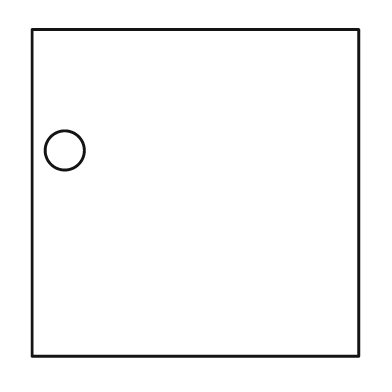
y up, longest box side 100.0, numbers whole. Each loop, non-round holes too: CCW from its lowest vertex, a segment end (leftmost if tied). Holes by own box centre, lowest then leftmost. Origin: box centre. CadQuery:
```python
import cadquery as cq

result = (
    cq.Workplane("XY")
    .moveTo(-50.0, -50.0)
    .lineTo(50.0, -50.0)
    .lineTo(50.0, 50.0)
    .lineTo(-50.0, 50.0)
    .close()
    .moveTo(-40.0, 13.0)
    .circle(6.0)
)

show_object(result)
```